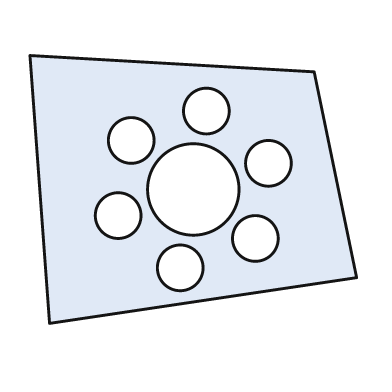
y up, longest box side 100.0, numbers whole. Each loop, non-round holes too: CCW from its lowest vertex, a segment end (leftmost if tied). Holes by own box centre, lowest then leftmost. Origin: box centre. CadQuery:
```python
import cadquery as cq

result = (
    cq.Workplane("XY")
    .moveTo(-44.0, -41.0)
    .lineTo(50.0, -27.0)
    .lineTo(37.0, 36.0)
    .lineTo(-50.0, 41.0)
    .close()
    .moveTo(-4.0, -24.0)
    .circle(7.0)
    .moveTo(19.0, -15.0)
    .circle(7.0)
    .moveTo(-23.0, -8.0)
    .circle(7.0)
    .moveTo(0.0, 0.0)
    .circle(14.0)
    .moveTo(23.0, 8.0)
    .circle(7.0)
    .moveTo(-19.0, 15.0)
    .circle(7.0)
    .moveTo(4.0, 24.0)
    .circle(7.0)
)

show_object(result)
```